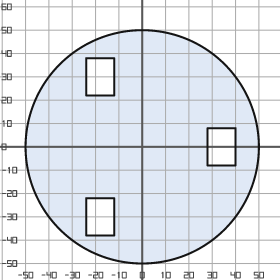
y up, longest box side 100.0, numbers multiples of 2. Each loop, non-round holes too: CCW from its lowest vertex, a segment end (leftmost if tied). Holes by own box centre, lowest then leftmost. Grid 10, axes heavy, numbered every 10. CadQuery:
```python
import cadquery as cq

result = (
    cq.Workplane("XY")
    .moveTo(0.0, 0.0)
    .circle(50.0)
    .moveTo(-24.0, -38.0)
    .lineTo(-12.0, -38.0)
    .lineTo(-12.0, -22.0)
    .lineTo(-24.0, -22.0)
    .close()
    .moveTo(28.0, -8.0)
    .lineTo(40.0, -8.0)
    .lineTo(40.0, 8.0)
    .lineTo(28.0, 8.0)
    .close()
    .moveTo(-24.0, 22.0)
    .lineTo(-12.0, 22.0)
    .lineTo(-12.0, 38.0)
    .lineTo(-24.0, 38.0)
    .close()
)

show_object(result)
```